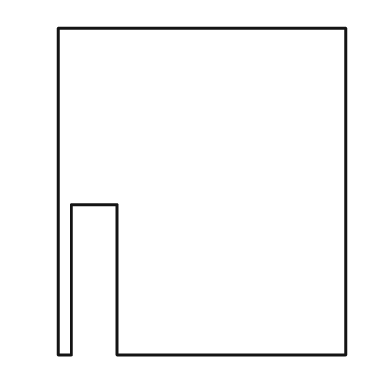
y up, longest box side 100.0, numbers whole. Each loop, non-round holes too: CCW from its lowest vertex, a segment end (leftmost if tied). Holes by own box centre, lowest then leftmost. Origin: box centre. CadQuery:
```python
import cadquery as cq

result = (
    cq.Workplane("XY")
    .moveTo(-44.0, -50.0)
    .lineTo(-40.0, -50.0)
    .lineTo(-40.0, -4.0)
    .lineTo(-26.0, -4.0)
    .lineTo(-26.0, -50.0)
    .lineTo(44.0, -50.0)
    .lineTo(44.0, 50.0)
    .lineTo(-44.0, 50.0)
    .close()
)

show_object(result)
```